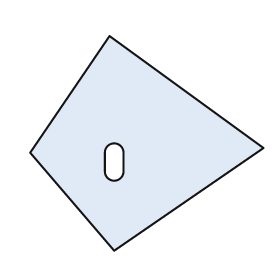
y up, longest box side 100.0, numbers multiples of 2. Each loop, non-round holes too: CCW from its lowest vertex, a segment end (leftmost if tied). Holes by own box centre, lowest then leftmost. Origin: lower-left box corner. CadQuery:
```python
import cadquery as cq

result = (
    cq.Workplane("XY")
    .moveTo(36.0, 0.0)
    .lineTo(100.0, 44.0)
    .lineTo(34.0, 92.0)
    .lineTo(0.0, 42.0)
    .close()
    .moveTo(32.0, 34.0)
    .threePointArc((36.0, 30.0), (40.0, 34.0))
    .lineTo(40.0, 42.0)
    .threePointArc((36.0, 46.0), (32.0, 42.0))
    .close()
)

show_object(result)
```